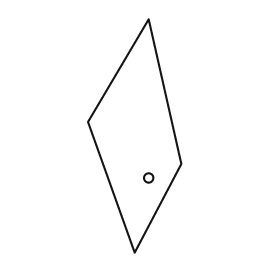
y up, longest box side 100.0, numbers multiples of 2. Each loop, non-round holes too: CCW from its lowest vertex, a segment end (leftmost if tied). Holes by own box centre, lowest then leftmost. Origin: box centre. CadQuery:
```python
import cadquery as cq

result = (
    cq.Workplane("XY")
    .moveTo(0.0, -50.0)
    .lineTo(20.0, -12.0)
    .lineTo(6.0, 50.0)
    .lineTo(-20.0, 6.0)
    .close()
    .moveTo(6.0, -18.0)
    .circle(2.0)
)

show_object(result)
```